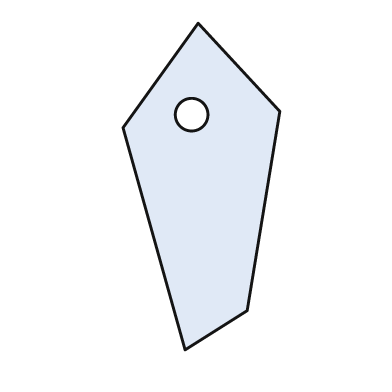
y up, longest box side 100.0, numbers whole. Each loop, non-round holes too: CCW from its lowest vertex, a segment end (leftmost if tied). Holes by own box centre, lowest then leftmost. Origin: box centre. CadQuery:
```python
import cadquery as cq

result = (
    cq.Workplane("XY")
    .moveTo(-5.0, -50.0)
    .lineTo(14.0, -38.0)
    .lineTo(24.0, 23.0)
    .lineTo(-1.0, 50.0)
    .lineTo(-24.0, 18.0)
    .close()
    .moveTo(-3.0, 22.0)
    .circle(5.0)
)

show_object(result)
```